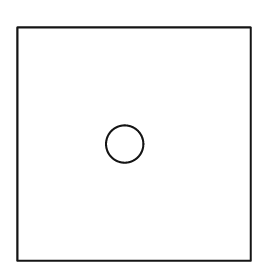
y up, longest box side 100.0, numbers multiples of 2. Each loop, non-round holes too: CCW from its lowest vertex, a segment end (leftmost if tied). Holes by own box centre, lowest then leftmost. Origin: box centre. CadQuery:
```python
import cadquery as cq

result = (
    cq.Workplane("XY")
    .moveTo(-50.0, -50.0)
    .lineTo(50.0, -50.0)
    .lineTo(50.0, 50.0)
    .lineTo(-50.0, 50.0)
    .close()
    .moveTo(-4.0, 0.0)
    .circle(8.0)
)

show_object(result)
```